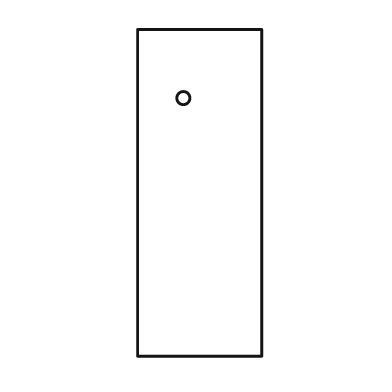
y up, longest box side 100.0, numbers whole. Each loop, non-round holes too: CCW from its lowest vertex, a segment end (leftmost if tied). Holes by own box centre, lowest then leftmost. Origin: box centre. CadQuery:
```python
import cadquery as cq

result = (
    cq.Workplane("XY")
    .moveTo(-19.0, -50.0)
    .lineTo(19.0, -50.0)
    .lineTo(19.0, 50.0)
    .lineTo(-19.0, 50.0)
    .close()
    .moveTo(-5.0, 29.0)
    .circle(2.0)
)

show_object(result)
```